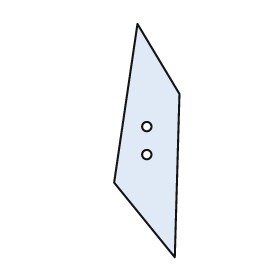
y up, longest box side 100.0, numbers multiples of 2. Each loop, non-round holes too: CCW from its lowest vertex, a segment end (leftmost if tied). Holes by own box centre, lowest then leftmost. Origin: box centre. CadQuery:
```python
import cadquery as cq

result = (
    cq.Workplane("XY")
    .moveTo(12.0, -50.0)
    .lineTo(14.0, 20.0)
    .lineTo(-4.0, 50.0)
    .lineTo(-14.0, -18.0)
    .close()
    .moveTo(0.0, -6.0)
    .circle(2.0)
    .moveTo(0.0, 6.0)
    .circle(2.0)
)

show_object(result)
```